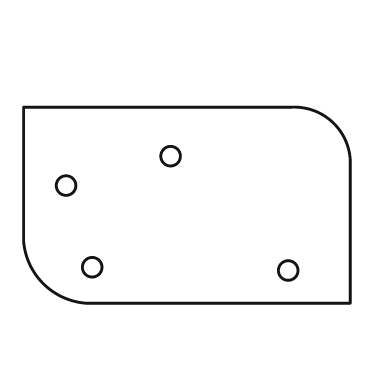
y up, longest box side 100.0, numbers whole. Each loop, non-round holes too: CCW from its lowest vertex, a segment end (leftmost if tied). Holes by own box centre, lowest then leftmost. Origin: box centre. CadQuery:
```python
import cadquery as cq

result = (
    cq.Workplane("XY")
    .moveTo(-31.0, -30.0)
    .lineTo(50.0, -30.0)
    .lineTo(50.0, 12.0)
    .threePointArc((45.0, 25.0), (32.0, 30.0))
    .lineTo(-50.0, 30.0)
    .lineTo(-50.0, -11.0)
    .threePointArc((-44.0, -24.0), (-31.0, -30.0))
    .close()
    .moveTo(31.0, -20.0)
    .circle(3.0)
    .moveTo(-29.0, -19.0)
    .circle(3.0)
    .moveTo(-37.0, 6.0)
    .circle(3.0)
    .moveTo(-5.0, 15.0)
    .circle(3.0)
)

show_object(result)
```